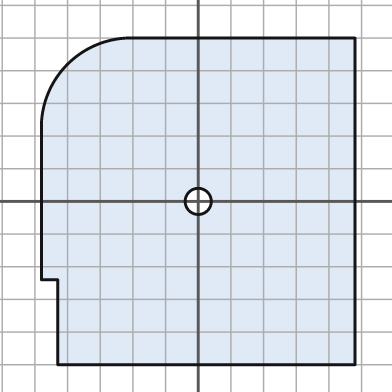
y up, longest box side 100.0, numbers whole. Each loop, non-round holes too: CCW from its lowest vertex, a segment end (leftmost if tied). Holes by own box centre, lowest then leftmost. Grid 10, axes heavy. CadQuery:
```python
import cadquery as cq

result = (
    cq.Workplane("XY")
    .moveTo(-43.0, -50.0)
    .lineTo(48.0, -50.0)
    .lineTo(48.0, 50.0)
    .lineTo(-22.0, 50.0)
    .threePointArc((-40.0, 42.0), (-48.0, 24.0))
    .lineTo(-48.0, -24.0)
    .lineTo(-43.0, -24.0)
    .close()
    .moveTo(0.0, 0.0)
    .circle(4.0)
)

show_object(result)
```